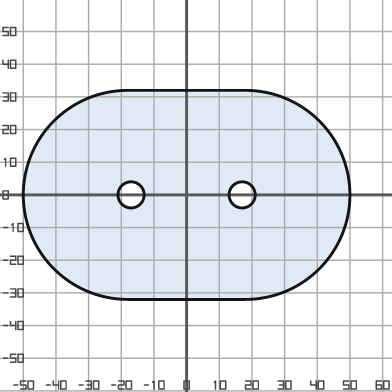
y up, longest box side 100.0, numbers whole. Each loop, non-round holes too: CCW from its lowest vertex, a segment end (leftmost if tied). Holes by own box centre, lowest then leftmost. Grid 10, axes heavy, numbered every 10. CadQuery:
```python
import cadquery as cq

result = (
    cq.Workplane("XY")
    .moveTo(-18.0, -32.0)
    .lineTo(18.0, -32.0)
    .threePointArc((50.0, 0.0), (18.0, 32.0))
    .lineTo(-18.0, 32.0)
    .threePointArc((-50.0, 0.0), (-18.0, -32.0))
    .close()
    .moveTo(-17.0, 0.0)
    .circle(4.0)
    .moveTo(17.0, 0.0)
    .circle(4.0)
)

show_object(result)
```